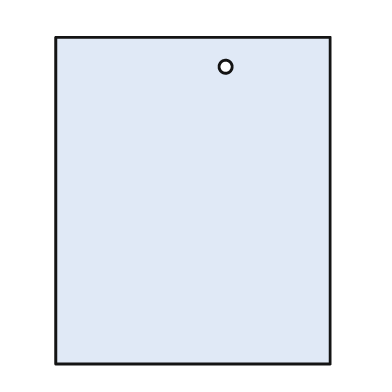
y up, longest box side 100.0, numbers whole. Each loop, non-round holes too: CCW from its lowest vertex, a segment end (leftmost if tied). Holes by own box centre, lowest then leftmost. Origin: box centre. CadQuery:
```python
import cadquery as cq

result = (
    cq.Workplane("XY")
    .moveTo(-42.0, -50.0)
    .lineTo(42.0, -50.0)
    .lineTo(42.0, 50.0)
    .lineTo(-42.0, 50.0)
    .close()
    .moveTo(10.0, 41.0)
    .circle(2.0)
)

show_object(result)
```